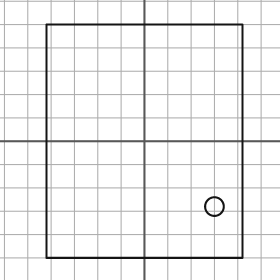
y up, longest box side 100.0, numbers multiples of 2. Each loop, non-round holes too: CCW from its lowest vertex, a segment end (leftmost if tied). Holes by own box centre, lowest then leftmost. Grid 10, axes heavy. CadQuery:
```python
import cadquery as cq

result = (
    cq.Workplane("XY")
    .moveTo(-42.0, -50.0)
    .lineTo(42.0, -50.0)
    .lineTo(42.0, 50.0)
    .lineTo(-42.0, 50.0)
    .close()
    .moveTo(30.0, -28.0)
    .circle(4.0)
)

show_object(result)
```